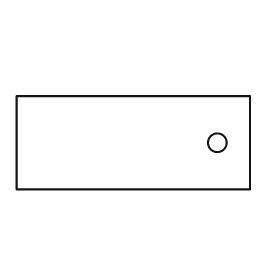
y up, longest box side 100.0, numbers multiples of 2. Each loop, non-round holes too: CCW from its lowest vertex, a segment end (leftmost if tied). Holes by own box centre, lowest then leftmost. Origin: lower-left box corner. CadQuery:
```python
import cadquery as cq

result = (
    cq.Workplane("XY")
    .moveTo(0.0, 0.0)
    .lineTo(100.0, 0.0)
    .lineTo(100.0, 40.0)
    .lineTo(0.0, 40.0)
    .close()
    .moveTo(86.0, 20.0)
    .circle(4.0)
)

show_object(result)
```